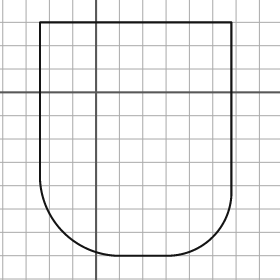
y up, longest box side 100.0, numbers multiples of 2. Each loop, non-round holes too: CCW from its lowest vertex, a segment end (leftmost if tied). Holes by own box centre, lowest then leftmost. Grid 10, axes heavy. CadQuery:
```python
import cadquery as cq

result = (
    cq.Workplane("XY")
    .moveTo(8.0, -70.0)
    .lineTo(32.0, -70.0)
    .threePointArc((50.0, -62.0), (58.0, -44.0))
    .lineTo(58.0, 30.0)
    .lineTo(-24.0, 30.0)
    .lineTo(-24.0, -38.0)
    .threePointArc((-14.0, -60.0), (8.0, -70.0))
    .close()
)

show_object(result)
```